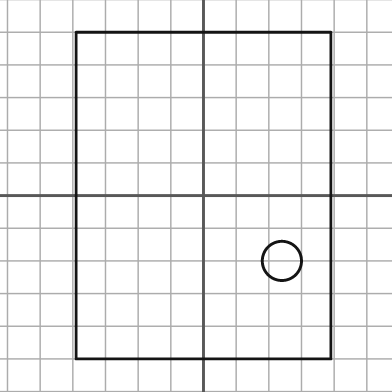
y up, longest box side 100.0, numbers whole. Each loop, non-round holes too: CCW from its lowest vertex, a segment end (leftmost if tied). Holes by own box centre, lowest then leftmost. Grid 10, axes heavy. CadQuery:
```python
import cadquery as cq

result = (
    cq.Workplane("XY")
    .moveTo(-39.0, -50.0)
    .lineTo(39.0, -50.0)
    .lineTo(39.0, 50.0)
    .lineTo(-39.0, 50.0)
    .close()
    .moveTo(24.0, -20.0)
    .circle(6.0)
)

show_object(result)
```